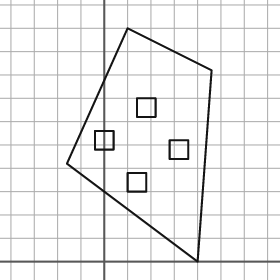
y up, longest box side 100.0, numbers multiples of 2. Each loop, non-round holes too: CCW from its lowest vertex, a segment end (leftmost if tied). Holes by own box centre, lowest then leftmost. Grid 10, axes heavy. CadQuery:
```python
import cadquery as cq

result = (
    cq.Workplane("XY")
    .moveTo(40.0, 0.0)
    .lineTo(46.0, 82.0)
    .lineTo(10.0, 100.0)
    .lineTo(-16.0, 42.0)
    .close()
    .moveTo(10.0, 30.0)
    .lineTo(18.0, 30.0)
    .lineTo(18.0, 38.0)
    .lineTo(10.0, 38.0)
    .close()
    .moveTo(28.0, 44.0)
    .lineTo(36.0, 44.0)
    .lineTo(36.0, 52.0)
    .lineTo(28.0, 52.0)
    .close()
    .moveTo(-4.0, 48.0)
    .lineTo(4.0, 48.0)
    .lineTo(4.0, 56.0)
    .lineTo(-4.0, 56.0)
    .close()
    .moveTo(14.0, 62.0)
    .lineTo(22.0, 62.0)
    .lineTo(22.0, 70.0)
    .lineTo(14.0, 70.0)
    .close()
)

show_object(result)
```